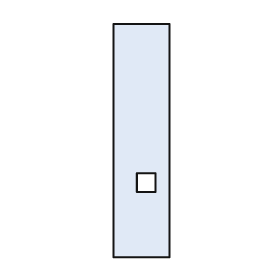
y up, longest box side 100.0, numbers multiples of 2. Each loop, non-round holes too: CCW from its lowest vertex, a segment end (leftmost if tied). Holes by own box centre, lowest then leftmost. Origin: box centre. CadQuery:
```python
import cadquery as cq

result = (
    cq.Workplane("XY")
    .moveTo(-12.0, -50.0)
    .lineTo(12.0, -50.0)
    .lineTo(12.0, 50.0)
    .lineTo(-12.0, 50.0)
    .close()
    .moveTo(-2.0, -22.0)
    .lineTo(6.0, -22.0)
    .lineTo(6.0, -14.0)
    .lineTo(-2.0, -14.0)
    .close()
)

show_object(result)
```